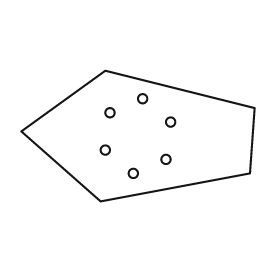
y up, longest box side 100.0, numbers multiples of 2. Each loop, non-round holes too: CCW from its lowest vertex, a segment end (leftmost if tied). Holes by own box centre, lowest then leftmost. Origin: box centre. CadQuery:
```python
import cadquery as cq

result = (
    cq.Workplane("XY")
    .moveTo(-16.0, -28.0)
    .lineTo(48.0, -16.0)
    .lineTo(50.0, 12.0)
    .lineTo(-14.0, 28.0)
    .lineTo(-50.0, 2.0)
    .close()
    .moveTo(-2.0, -16.0)
    .circle(2.0)
    .moveTo(12.0, -10.0)
    .circle(2.0)
    .moveTo(-14.0, -6.0)
    .circle(2.0)
    .moveTo(14.0, 6.0)
    .circle(2.0)
    .moveTo(-12.0, 10.0)
    .circle(2.0)
    .moveTo(2.0, 16.0)
    .circle(2.0)
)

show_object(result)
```